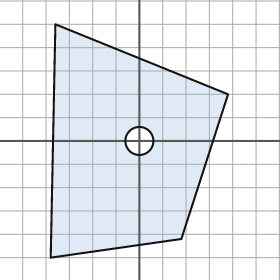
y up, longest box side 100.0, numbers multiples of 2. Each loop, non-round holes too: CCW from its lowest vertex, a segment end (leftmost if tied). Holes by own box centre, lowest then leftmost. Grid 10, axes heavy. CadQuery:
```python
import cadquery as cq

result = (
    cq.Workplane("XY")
    .moveTo(-38.0, -50.0)
    .lineTo(18.0, -42.0)
    .lineTo(38.0, 20.0)
    .lineTo(-36.0, 50.0)
    .close()
    .moveTo(0.0, 0.0)
    .circle(6.0)
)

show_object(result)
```